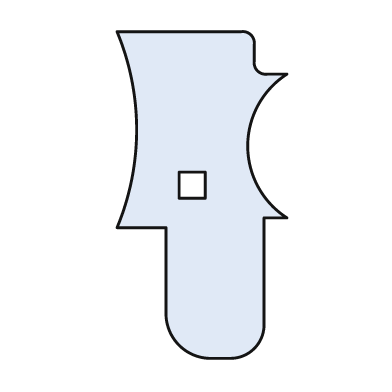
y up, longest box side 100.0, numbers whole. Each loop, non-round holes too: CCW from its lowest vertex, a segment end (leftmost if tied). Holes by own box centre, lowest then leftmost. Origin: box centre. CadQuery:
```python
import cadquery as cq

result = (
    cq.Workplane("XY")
    .moveTo(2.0, -50.0)
    .lineTo(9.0, -50.0)
    .threePointArc((16.0, -47.0), (19.0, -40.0))
    .lineTo(19.0, -7.0)
    .lineTo(26.0, -7.0)
    .threePointArc((14.0, 15.0), (26.0, 37.0))
    .lineTo(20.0, 37.0)
    .threePointArc((17.0, 38.0), (16.0, 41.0))
    .lineTo(16.0, 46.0)
    .threePointArc((15.0, 49.0), (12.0, 50.0))
    .lineTo(-26.0, 50.0)
    .threePointArc((-20.0, 20.0), (-26.0, -10.0))
    .lineTo(-11.0, -10.0)
    .lineTo(-11.0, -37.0)
    .threePointArc((-7.0, -46.0), (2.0, -50.0))
    .close()
    .moveTo(-7.0, -1.0)
    .lineTo(1.0, -1.0)
    .lineTo(1.0, 7.0)
    .lineTo(-7.0, 7.0)
    .close()
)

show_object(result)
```